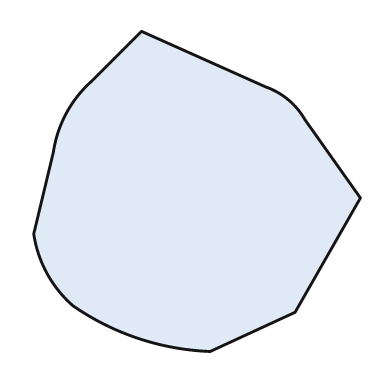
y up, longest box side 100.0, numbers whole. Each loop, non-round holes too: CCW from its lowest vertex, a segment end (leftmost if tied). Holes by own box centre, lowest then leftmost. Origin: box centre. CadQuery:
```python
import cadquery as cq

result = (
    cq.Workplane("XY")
    .moveTo(4.0, -49.0)
    .lineTo(30.0, -37.0)
    .lineTo(50.0, -2.0)
    .lineTo(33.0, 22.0)
    .threePointArc((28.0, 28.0), (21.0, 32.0))
    .lineTo(-17.0, 49.0)
    .lineTo(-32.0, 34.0)
    .threePointArc((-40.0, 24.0), (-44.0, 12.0))
    .lineTo(-50.0, -13.0)
    .threePointArc((-46.0, -25.0), (-38.0, -35.0))
    .threePointArc((-18.0, -45.0), (4.0, -49.0))
    .close()
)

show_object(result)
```